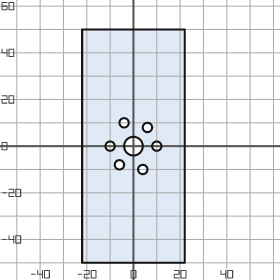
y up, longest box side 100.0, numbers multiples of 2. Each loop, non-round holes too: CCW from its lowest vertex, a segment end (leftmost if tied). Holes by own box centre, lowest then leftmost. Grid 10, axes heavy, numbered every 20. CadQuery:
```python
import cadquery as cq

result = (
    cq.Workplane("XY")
    .moveTo(-22.0, -50.0)
    .lineTo(22.0, -50.0)
    .lineTo(22.0, 50.0)
    .lineTo(-22.0, 50.0)
    .close()
    .moveTo(4.0, -10.0)
    .circle(2.0)
    .moveTo(-6.0, -8.0)
    .circle(2.0)
    .moveTo(-10.0, 0.0)
    .circle(2.0)
    .moveTo(0.0, 0.0)
    .circle(4.0)
    .moveTo(10.0, 0.0)
    .circle(2.0)
    .moveTo(6.0, 8.0)
    .circle(2.0)
    .moveTo(-4.0, 10.0)
    .circle(2.0)
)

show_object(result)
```